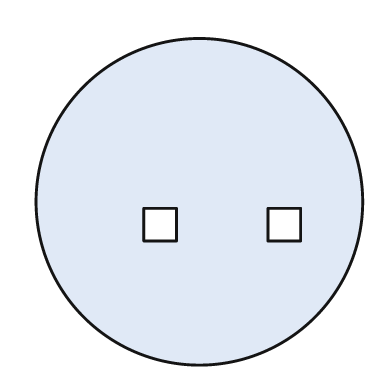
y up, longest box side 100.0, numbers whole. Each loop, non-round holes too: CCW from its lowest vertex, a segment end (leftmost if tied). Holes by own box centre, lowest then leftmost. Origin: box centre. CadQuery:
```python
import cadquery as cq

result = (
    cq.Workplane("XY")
    .moveTo(0.0, 0.0)
    .circle(50.0)
    .moveTo(-17.0, -12.0)
    .lineTo(-7.0, -12.0)
    .lineTo(-7.0, -2.0)
    .lineTo(-17.0, -2.0)
    .close()
    .moveTo(21.0, -12.0)
    .lineTo(31.0, -12.0)
    .lineTo(31.0, -2.0)
    .lineTo(21.0, -2.0)
    .close()
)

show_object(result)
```